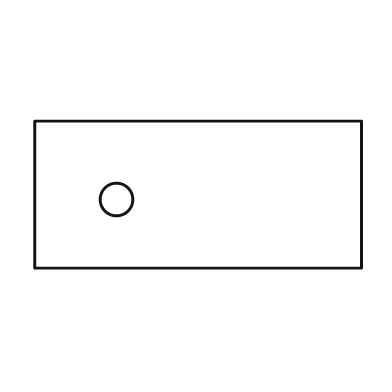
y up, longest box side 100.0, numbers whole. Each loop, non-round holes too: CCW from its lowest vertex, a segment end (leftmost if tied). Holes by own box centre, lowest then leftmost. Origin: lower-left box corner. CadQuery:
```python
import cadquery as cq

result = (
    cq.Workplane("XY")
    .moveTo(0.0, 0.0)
    .lineTo(100.0, 0.0)
    .lineTo(100.0, 45.0)
    .lineTo(0.0, 45.0)
    .close()
    .moveTo(25.0, 21.0)
    .circle(5.0)
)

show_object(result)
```